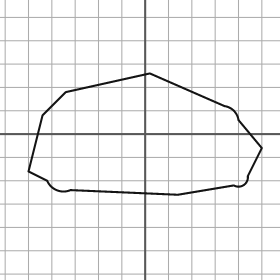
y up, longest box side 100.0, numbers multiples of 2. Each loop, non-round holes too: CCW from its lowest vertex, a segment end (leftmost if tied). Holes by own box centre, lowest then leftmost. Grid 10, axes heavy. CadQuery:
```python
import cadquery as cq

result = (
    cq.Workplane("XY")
    .moveTo(14.0, -26.0)
    .lineTo(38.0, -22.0)
    .threePointArc((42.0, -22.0), (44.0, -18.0))
    .lineTo(50.0, -6.0)
    .lineTo(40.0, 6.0)
    .threePointArc((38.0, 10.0), (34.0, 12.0))
    .lineTo(2.0, 26.0)
    .lineTo(-34.0, 18.0)
    .lineTo(-44.0, 8.0)
    .lineTo(-50.0, -16.0)
    .lineTo(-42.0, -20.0)
    .threePointArc((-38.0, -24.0), (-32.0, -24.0))
    .close()
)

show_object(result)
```